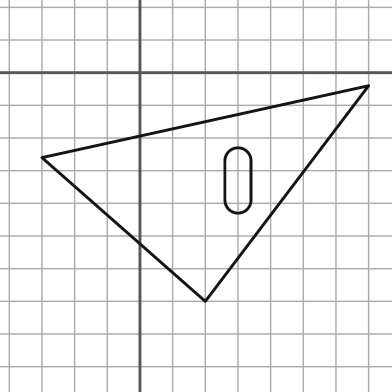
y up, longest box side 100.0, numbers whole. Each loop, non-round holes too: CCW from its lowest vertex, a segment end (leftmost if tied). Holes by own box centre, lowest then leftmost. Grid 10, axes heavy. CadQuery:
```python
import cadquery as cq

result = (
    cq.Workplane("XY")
    .moveTo(20.0, -70.0)
    .lineTo(70.0, -4.0)
    .lineTo(-30.0, -26.0)
    .close()
    .moveTo(26.0, -39.0)
    .threePointArc((30.0, -43.0), (34.0, -39.0))
    .lineTo(34.0, -27.0)
    .threePointArc((30.0, -23.0), (26.0, -27.0))
    .close()
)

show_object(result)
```